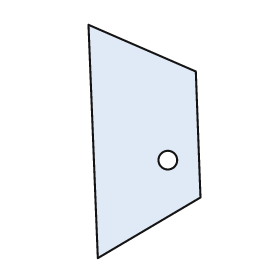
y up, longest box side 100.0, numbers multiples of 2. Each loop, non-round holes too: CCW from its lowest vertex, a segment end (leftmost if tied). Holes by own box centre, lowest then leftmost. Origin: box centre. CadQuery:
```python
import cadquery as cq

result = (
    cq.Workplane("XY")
    .moveTo(-20.0, -50.0)
    .lineTo(24.0, -24.0)
    .lineTo(22.0, 30.0)
    .lineTo(-24.0, 50.0)
    .close()
    .moveTo(10.0, -8.0)
    .circle(4.0)
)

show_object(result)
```